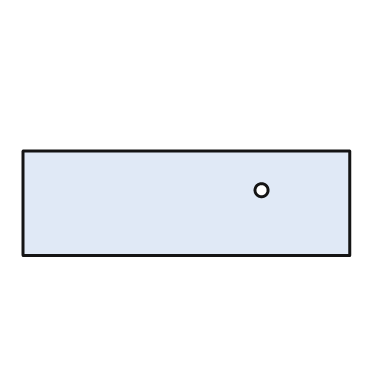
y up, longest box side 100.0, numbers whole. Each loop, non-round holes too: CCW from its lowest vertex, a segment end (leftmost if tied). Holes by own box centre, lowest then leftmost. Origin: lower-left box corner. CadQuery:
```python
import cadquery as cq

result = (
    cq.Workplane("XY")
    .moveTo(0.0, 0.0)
    .lineTo(100.0, 0.0)
    .lineTo(100.0, 32.0)
    .lineTo(0.0, 32.0)
    .close()
    .moveTo(73.0, 20.0)
    .circle(2.0)
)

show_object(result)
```